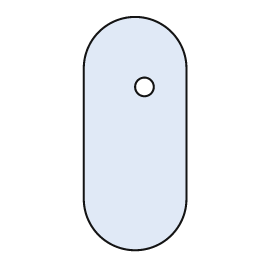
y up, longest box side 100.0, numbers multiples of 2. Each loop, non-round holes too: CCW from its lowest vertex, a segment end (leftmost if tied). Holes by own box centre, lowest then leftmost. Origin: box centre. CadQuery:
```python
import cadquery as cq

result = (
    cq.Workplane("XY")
    .moveTo(-22.0, -28.0)
    .threePointArc((0.0, -50.0), (22.0, -28.0))
    .lineTo(22.0, 28.0)
    .threePointArc((0.0, 50.0), (-22.0, 28.0))
    .close()
    .moveTo(4.0, 20.0)
    .circle(4.0)
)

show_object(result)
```